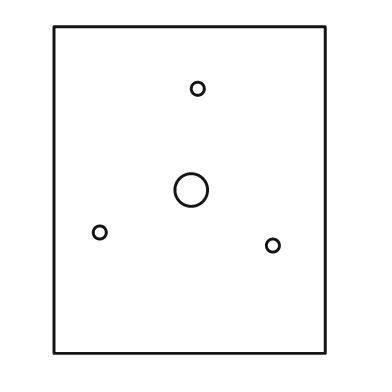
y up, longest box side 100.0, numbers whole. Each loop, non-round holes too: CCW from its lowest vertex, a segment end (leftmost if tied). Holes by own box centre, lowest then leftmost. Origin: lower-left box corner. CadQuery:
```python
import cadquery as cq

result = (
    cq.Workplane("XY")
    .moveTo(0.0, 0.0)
    .lineTo(83.0, 0.0)
    .lineTo(83.0, 100.0)
    .lineTo(0.0, 100.0)
    .close()
    .moveTo(67.0, 33.0)
    .circle(2.0)
    .moveTo(14.0, 37.0)
    .circle(2.0)
    .moveTo(42.0, 50.0)
    .circle(5.0)
    .moveTo(44.0, 81.0)
    .circle(2.0)
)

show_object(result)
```